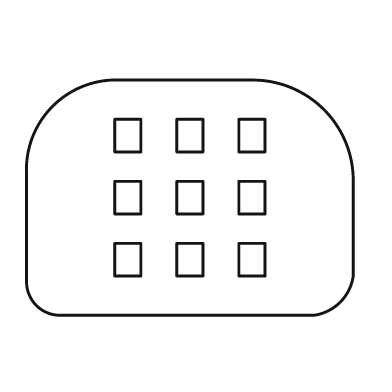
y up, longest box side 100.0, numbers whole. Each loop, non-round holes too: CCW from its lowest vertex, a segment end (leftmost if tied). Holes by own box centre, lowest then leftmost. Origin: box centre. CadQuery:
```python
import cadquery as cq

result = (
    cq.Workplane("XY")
    .moveTo(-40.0, -36.0)
    .lineTo(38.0, -36.0)
    .threePointArc((46.0, -32.0), (50.0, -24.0))
    .lineTo(50.0, 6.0)
    .threePointArc((41.0, 27.0), (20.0, 36.0))
    .lineTo(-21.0, 36.0)
    .threePointArc((-42.0, 28.0), (-50.0, 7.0))
    .lineTo(-50.0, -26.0)
    .threePointArc((-47.0, -33.0), (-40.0, -36.0))
    .close()
    .moveTo(-23.0, -24.0)
    .lineTo(-15.0, -24.0)
    .lineTo(-15.0, -14.0)
    .lineTo(-23.0, -14.0)
    .close()
    .moveTo(-4.0, -24.0)
    .lineTo(4.0, -24.0)
    .lineTo(4.0, -14.0)
    .lineTo(-4.0, -14.0)
    .close()
    .moveTo(15.0, -24.0)
    .lineTo(23.0, -24.0)
    .lineTo(23.0, -14.0)
    .lineTo(15.0, -14.0)
    .close()
    .moveTo(-23.0, -5.0)
    .lineTo(-15.0, -5.0)
    .lineTo(-15.0, 5.0)
    .lineTo(-23.0, 5.0)
    .close()
    .moveTo(-4.0, -5.0)
    .lineTo(4.0, -5.0)
    .lineTo(4.0, 5.0)
    .lineTo(-4.0, 5.0)
    .close()
    .moveTo(15.0, -5.0)
    .lineTo(23.0, -5.0)
    .lineTo(23.0, 5.0)
    .lineTo(15.0, 5.0)
    .close()
    .moveTo(-23.0, 14.0)
    .lineTo(-15.0, 14.0)
    .lineTo(-15.0, 24.0)
    .lineTo(-23.0, 24.0)
    .close()
    .moveTo(-4.0, 14.0)
    .lineTo(4.0, 14.0)
    .lineTo(4.0, 24.0)
    .lineTo(-4.0, 24.0)
    .close()
    .moveTo(15.0, 14.0)
    .lineTo(23.0, 14.0)
    .lineTo(23.0, 24.0)
    .lineTo(15.0, 24.0)
    .close()
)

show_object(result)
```